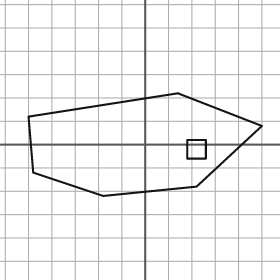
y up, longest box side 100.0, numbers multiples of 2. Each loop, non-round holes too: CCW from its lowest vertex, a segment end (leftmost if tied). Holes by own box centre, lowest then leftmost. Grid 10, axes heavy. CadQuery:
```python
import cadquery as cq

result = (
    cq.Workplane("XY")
    .moveTo(-18.0, -22.0)
    .lineTo(22.0, -18.0)
    .lineTo(50.0, 8.0)
    .lineTo(14.0, 22.0)
    .lineTo(-50.0, 12.0)
    .lineTo(-48.0, -12.0)
    .close()
    .moveTo(18.0, -6.0)
    .lineTo(26.0, -6.0)
    .lineTo(26.0, 2.0)
    .lineTo(18.0, 2.0)
    .close()
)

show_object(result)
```